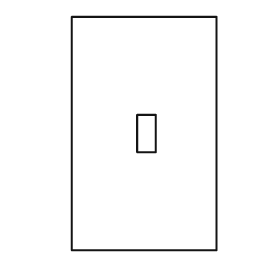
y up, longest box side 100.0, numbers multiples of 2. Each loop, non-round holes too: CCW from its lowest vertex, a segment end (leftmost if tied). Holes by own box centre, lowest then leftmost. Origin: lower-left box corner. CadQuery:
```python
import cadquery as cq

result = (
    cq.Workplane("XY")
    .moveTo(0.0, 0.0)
    .lineTo(62.0, 0.0)
    .lineTo(62.0, 100.0)
    .lineTo(0.0, 100.0)
    .close()
    .moveTo(28.0, 42.0)
    .lineTo(36.0, 42.0)
    .lineTo(36.0, 58.0)
    .lineTo(28.0, 58.0)
    .close()
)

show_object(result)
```